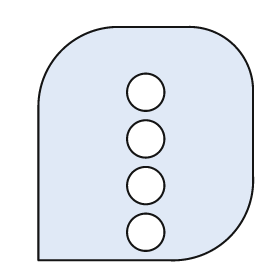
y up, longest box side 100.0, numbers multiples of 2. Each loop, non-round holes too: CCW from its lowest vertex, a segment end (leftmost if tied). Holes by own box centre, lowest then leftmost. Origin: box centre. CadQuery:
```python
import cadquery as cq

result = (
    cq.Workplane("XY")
    .moveTo(-46.0, -50.0)
    .lineTo(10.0, -50.0)
    .threePointArc((36.0, -40.0), (46.0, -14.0))
    .lineTo(46.0, 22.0)
    .threePointArc((38.0, 42.0), (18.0, 50.0))
    .lineTo(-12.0, 50.0)
    .threePointArc((-36.0, 40.0), (-46.0, 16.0))
    .close()
    .moveTo(0.0, -38.0)
    .circle(8.0)
    .moveTo(0.0, -18.0)
    .circle(8.0)
    .moveTo(0.0, 2.0)
    .circle(8.0)
    .moveTo(0.0, 22.0)
    .circle(8.0)
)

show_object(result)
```